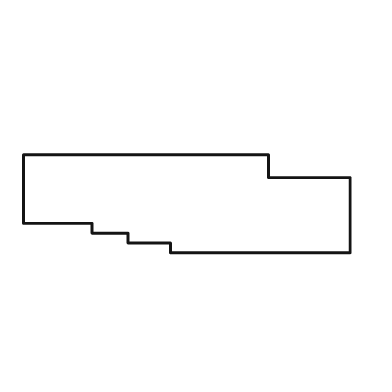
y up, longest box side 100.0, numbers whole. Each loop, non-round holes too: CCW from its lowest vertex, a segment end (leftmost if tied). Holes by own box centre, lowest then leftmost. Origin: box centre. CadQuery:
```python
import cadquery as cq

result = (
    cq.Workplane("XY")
    .moveTo(-5.0, -15.0)
    .lineTo(50.0, -15.0)
    .lineTo(50.0, 8.0)
    .lineTo(25.0, 8.0)
    .lineTo(25.0, 15.0)
    .lineTo(-50.0, 15.0)
    .lineTo(-50.0, -6.0)
    .lineTo(-29.0, -6.0)
    .lineTo(-29.0, -9.0)
    .lineTo(-18.0, -9.0)
    .lineTo(-18.0, -12.0)
    .lineTo(-5.0, -12.0)
    .close()
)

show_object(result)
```